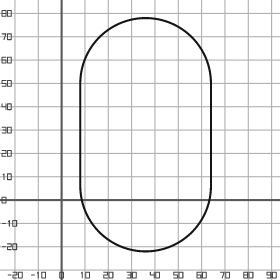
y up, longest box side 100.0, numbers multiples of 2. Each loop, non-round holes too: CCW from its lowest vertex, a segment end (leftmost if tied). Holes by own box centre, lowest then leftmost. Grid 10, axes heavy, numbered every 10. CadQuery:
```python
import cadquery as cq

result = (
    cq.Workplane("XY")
    .moveTo(8.0, 6.0)
    .threePointArc((36.0, -22.0), (64.0, 6.0))
    .lineTo(64.0, 50.0)
    .threePointArc((36.0, 78.0), (8.0, 50.0))
    .close()
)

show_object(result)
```